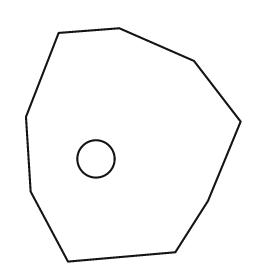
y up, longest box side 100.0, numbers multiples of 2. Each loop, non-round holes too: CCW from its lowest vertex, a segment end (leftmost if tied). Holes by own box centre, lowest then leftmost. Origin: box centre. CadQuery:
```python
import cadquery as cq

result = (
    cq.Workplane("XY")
    .moveTo(-28.0, -50.0)
    .lineTo(18.0, -46.0)
    .lineTo(32.0, -24.0)
    .lineTo(46.0, 10.0)
    .lineTo(26.0, 36.0)
    .lineTo(-6.0, 50.0)
    .lineTo(-32.0, 48.0)
    .lineTo(-46.0, 12.0)
    .lineTo(-44.0, -20.0)
    .close()
    .moveTo(-16.0, -6.0)
    .circle(8.0)
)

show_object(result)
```